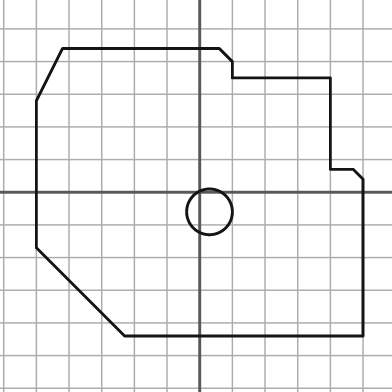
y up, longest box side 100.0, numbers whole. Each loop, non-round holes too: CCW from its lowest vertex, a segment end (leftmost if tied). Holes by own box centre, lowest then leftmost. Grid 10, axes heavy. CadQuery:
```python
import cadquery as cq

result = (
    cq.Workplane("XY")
    .moveTo(-23.0, -44.0)
    .lineTo(50.0, -44.0)
    .lineTo(50.0, 4.0)
    .lineTo(47.0, 7.0)
    .lineTo(40.0, 7.0)
    .lineTo(40.0, 35.0)
    .lineTo(10.0, 35.0)
    .lineTo(10.0, 40.0)
    .lineTo(6.0, 44.0)
    .lineTo(-42.0, 44.0)
    .lineTo(-50.0, 28.0)
    .lineTo(-50.0, -17.0)
    .close()
    .moveTo(3.0, -6.0)
    .circle(7.0)
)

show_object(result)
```